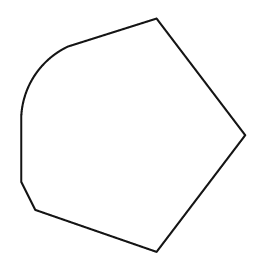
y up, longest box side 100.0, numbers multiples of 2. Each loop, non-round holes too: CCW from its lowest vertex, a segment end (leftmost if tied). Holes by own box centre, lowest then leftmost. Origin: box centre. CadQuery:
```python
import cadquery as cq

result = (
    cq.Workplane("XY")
    .moveTo(10.0, -50.0)
    .lineTo(48.0, 0.0)
    .lineTo(10.0, 50.0)
    .lineTo(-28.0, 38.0)
    .threePointArc((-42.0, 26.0), (-48.0, 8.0))
    .lineTo(-48.0, -20.0)
    .lineTo(-42.0, -32.0)
    .close()
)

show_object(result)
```